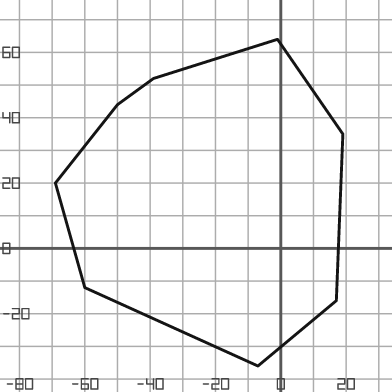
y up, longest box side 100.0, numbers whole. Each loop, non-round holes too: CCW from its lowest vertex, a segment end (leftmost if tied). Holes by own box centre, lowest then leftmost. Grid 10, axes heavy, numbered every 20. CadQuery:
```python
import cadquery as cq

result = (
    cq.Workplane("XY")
    .moveTo(-7.0, -36.0)
    .lineTo(17.0, -16.0)
    .lineTo(19.0, 35.0)
    .lineTo(-1.0, 64.0)
    .lineTo(-39.0, 52.0)
    .lineTo(-50.0, 44.0)
    .lineTo(-69.0, 20.0)
    .lineTo(-60.0, -12.0)
    .close()
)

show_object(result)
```